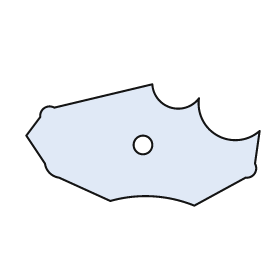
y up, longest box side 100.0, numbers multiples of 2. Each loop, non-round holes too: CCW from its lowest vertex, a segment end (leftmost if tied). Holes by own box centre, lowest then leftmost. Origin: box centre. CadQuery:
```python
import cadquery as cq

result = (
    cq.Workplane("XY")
    .moveTo(22.0, -26.0)
    .lineTo(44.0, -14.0)
    .threePointArc((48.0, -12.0), (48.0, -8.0))
    .lineTo(50.0, 6.0)
    .threePointArc((32.0, 4.0), (24.0, 20.0))
    .threePointArc((12.0, 16.0), (4.0, 26.0))
    .lineTo(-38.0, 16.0)
    .threePointArc((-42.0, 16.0), (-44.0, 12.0))
    .lineTo(-50.0, 4.0)
    .lineTo(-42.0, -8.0)
    .threePointArc((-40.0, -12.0), (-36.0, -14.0))
    .lineTo(-14.0, -24.0)
    .threePointArc((4.0, -22.0), (22.0, -26.0))
    .close()
    .moveTo(0.0, 0.0)
    .circle(4.0)
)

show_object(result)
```